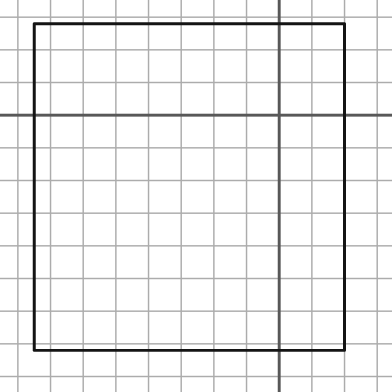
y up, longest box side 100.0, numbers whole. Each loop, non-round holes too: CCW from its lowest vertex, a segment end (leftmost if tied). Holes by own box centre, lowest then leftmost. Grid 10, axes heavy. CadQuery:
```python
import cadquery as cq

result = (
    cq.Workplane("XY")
    .moveTo(-75.0, -72.0)
    .lineTo(20.0, -72.0)
    .lineTo(20.0, 28.0)
    .lineTo(-75.0, 28.0)
    .close()
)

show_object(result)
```